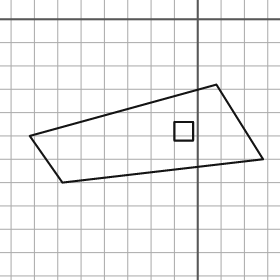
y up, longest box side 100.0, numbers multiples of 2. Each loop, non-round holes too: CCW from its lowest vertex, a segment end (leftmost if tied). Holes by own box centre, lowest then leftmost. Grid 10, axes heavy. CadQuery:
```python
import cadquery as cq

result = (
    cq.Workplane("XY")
    .moveTo(-58.0, -70.0)
    .lineTo(28.0, -60.0)
    .lineTo(8.0, -28.0)
    .lineTo(-72.0, -50.0)
    .close()
    .moveTo(-10.0, -52.0)
    .lineTo(-2.0, -52.0)
    .lineTo(-2.0, -44.0)
    .lineTo(-10.0, -44.0)
    .close()
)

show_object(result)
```